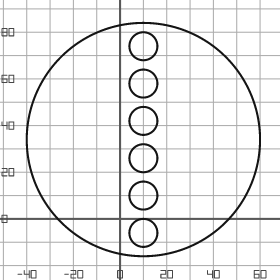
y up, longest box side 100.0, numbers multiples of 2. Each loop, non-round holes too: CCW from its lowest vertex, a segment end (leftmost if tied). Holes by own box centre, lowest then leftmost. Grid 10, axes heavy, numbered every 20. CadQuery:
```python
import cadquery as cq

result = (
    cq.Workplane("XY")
    .moveTo(10.0, 34.0)
    .circle(50.0)
    .moveTo(10.0, -6.0)
    .circle(6.0)
    .moveTo(10.0, 10.0)
    .circle(6.0)
    .moveTo(10.0, 26.0)
    .circle(6.0)
    .moveTo(10.0, 42.0)
    .circle(6.0)
    .moveTo(10.0, 58.0)
    .circle(6.0)
    .moveTo(10.0, 74.0)
    .circle(6.0)
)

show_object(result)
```